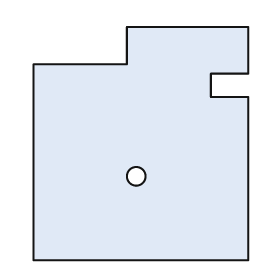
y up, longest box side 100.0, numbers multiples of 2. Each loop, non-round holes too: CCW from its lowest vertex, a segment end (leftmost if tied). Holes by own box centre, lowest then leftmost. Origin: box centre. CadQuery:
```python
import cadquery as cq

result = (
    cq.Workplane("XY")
    .moveTo(-46.0, -50.0)
    .lineTo(46.0, -50.0)
    .lineTo(46.0, 20.0)
    .lineTo(30.0, 20.0)
    .lineTo(30.0, 30.0)
    .lineTo(46.0, 30.0)
    .lineTo(46.0, 50.0)
    .lineTo(-6.0, 50.0)
    .lineTo(-6.0, 34.0)
    .lineTo(-46.0, 34.0)
    .close()
    .moveTo(-2.0, -14.0)
    .circle(4.0)
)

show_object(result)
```